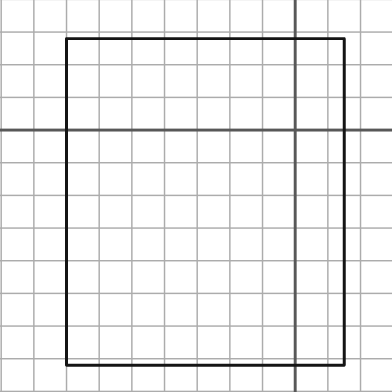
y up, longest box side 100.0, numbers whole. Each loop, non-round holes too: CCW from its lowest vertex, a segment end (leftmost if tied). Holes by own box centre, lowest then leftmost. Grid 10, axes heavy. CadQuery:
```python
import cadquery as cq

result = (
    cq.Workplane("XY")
    .moveTo(-70.0, -72.0)
    .lineTo(15.0, -72.0)
    .lineTo(15.0, 28.0)
    .lineTo(-70.0, 28.0)
    .close()
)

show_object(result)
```